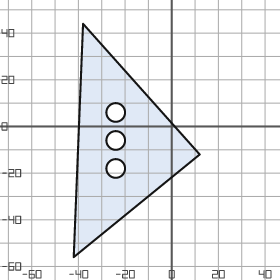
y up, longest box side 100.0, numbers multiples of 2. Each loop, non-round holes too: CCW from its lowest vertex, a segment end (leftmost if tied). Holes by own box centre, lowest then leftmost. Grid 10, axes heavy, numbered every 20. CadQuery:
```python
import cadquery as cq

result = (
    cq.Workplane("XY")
    .moveTo(-42.0, -56.0)
    .lineTo(12.0, -12.0)
    .lineTo(-38.0, 44.0)
    .close()
    .moveTo(-24.0, -18.0)
    .circle(4.0)
    .moveTo(-24.0, -6.0)
    .circle(4.0)
    .moveTo(-24.0, 6.0)
    .circle(4.0)
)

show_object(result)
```